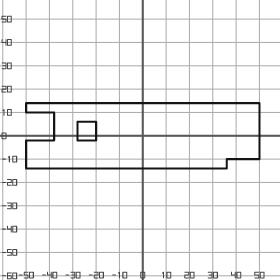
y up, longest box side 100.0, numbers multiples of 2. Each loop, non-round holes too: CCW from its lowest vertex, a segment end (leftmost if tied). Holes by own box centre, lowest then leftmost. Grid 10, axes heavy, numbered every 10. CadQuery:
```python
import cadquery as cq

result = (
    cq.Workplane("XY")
    .moveTo(-50.0, -14.0)
    .lineTo(36.0, -14.0)
    .lineTo(36.0, -10.0)
    .lineTo(50.0, -10.0)
    .lineTo(50.0, 14.0)
    .lineTo(-50.0, 14.0)
    .lineTo(-50.0, 10.0)
    .lineTo(-38.0, 10.0)
    .lineTo(-38.0, -2.0)
    .lineTo(-50.0, -2.0)
    .close()
    .moveTo(-28.0, -2.0)
    .lineTo(-20.0, -2.0)
    .lineTo(-20.0, 6.0)
    .lineTo(-28.0, 6.0)
    .close()
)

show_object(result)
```